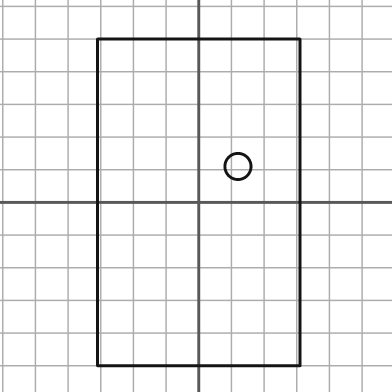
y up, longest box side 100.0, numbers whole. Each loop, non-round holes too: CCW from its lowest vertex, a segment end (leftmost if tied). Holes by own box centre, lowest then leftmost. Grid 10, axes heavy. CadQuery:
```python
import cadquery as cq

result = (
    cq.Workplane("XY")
    .moveTo(-31.0, -50.0)
    .lineTo(31.0, -50.0)
    .lineTo(31.0, 50.0)
    .lineTo(-31.0, 50.0)
    .close()
    .moveTo(12.0, 11.0)
    .circle(4.0)
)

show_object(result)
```